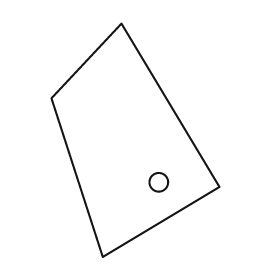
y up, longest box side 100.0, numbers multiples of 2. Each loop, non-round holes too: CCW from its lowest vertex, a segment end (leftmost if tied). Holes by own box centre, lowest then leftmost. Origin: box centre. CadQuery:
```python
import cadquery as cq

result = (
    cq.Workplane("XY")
    .moveTo(-14.0, -50.0)
    .lineTo(36.0, -20.0)
    .lineTo(-6.0, 50.0)
    .lineTo(-36.0, 18.0)
    .close()
    .moveTo(10.0, -18.0)
    .circle(4.0)
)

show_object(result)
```